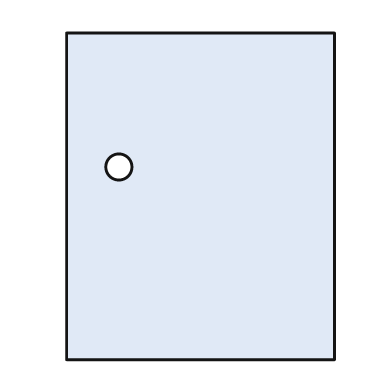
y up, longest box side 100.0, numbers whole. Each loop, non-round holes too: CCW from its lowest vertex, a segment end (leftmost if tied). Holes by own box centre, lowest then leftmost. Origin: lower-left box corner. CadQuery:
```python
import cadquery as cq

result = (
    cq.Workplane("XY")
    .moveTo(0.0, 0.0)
    .lineTo(82.0, 0.0)
    .lineTo(82.0, 100.0)
    .lineTo(0.0, 100.0)
    .close()
    .moveTo(16.0, 59.0)
    .circle(4.0)
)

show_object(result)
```